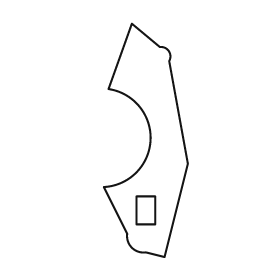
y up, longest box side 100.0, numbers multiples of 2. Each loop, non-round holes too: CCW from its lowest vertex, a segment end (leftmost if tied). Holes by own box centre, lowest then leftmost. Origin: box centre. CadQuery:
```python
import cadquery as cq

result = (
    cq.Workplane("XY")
    .moveTo(8.0, -50.0)
    .lineTo(18.0, -10.0)
    .lineTo(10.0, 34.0)
    .threePointArc((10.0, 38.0), (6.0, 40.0))
    .lineTo(-6.0, 50.0)
    .lineTo(-16.0, 22.0)
    .threePointArc((2.0, 0.0), (-18.0, -20.0))
    .lineTo(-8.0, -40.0)
    .threePointArc((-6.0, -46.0), (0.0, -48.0))
    .close()
    .moveTo(-4.0, -36.0)
    .lineTo(4.0, -36.0)
    .lineTo(4.0, -24.0)
    .lineTo(-4.0, -24.0)
    .close()
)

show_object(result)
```